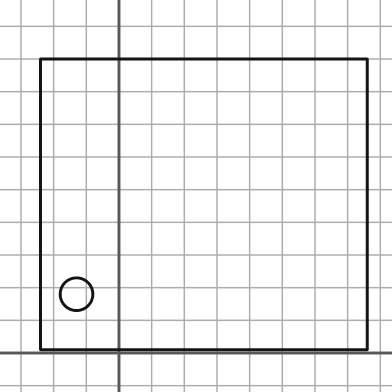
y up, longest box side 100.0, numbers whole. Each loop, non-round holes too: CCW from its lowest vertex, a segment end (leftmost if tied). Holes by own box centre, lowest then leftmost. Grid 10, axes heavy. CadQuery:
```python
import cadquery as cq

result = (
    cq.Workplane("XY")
    .moveTo(-24.0, 1.0)
    .lineTo(76.0, 1.0)
    .lineTo(76.0, 90.0)
    .lineTo(-24.0, 90.0)
    .close()
    .moveTo(-13.0, 18.0)
    .circle(5.0)
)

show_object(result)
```